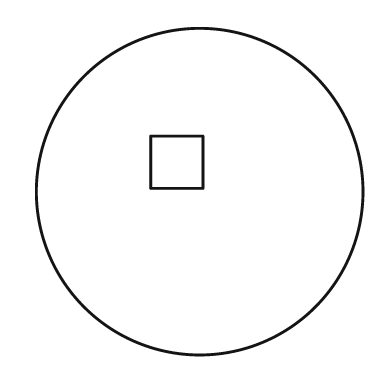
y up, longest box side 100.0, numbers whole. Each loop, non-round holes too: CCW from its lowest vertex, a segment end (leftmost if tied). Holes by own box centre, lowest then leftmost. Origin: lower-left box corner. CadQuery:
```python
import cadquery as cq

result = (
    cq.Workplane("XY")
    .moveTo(50.0, 50.0)
    .circle(50.0)
    .moveTo(35.0, 51.0)
    .lineTo(51.0, 51.0)
    .lineTo(51.0, 67.0)
    .lineTo(35.0, 67.0)
    .close()
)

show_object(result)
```